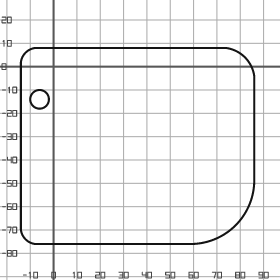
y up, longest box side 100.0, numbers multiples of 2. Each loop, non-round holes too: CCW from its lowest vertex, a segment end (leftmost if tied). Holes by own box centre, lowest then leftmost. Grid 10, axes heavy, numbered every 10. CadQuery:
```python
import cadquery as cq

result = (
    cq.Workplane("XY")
    .moveTo(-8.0, -76.0)
    .lineTo(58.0, -76.0)
    .threePointArc((78.0, -68.0), (86.0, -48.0))
    .lineTo(86.0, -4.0)
    .threePointArc((82.0, 4.0), (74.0, 8.0))
    .lineTo(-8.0, 8.0)
    .threePointArc((-12.0, 6.0), (-14.0, 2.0))
    .lineTo(-14.0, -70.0)
    .threePointArc((-12.0, -74.0), (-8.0, -76.0))
    .close()
    .moveTo(-6.0, -14.0)
    .circle(4.0)
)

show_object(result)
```